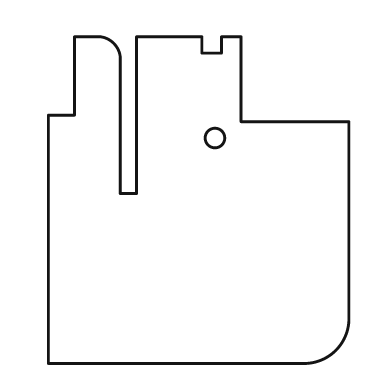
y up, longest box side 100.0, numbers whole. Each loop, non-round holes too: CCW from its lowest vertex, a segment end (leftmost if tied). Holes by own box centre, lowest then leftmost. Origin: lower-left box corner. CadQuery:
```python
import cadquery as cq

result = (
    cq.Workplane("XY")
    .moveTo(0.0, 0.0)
    .lineTo(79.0, 0.0)
    .threePointArc((88.0, 4.0), (92.0, 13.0))
    .lineTo(92.0, 74.0)
    .lineTo(59.0, 74.0)
    .lineTo(59.0, 100.0)
    .lineTo(53.0, 100.0)
    .lineTo(53.0, 95.0)
    .lineTo(47.0, 95.0)
    .lineTo(47.0, 100.0)
    .lineTo(27.0, 100.0)
    .lineTo(27.0, 52.0)
    .lineTo(22.0, 52.0)
    .lineTo(22.0, 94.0)
    .threePointArc((20.0, 98.0), (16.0, 100.0))
    .lineTo(8.0, 100.0)
    .lineTo(8.0, 76.0)
    .lineTo(0.0, 76.0)
    .close()
    .moveTo(51.0, 69.0)
    .circle(3.0)
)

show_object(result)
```